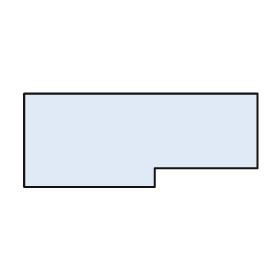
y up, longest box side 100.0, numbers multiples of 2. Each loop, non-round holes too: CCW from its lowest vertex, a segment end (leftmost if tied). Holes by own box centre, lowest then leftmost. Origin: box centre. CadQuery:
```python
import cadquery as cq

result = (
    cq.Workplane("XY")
    .moveTo(-50.0, -20.0)
    .lineTo(6.0, -20.0)
    .lineTo(6.0, -12.0)
    .lineTo(50.0, -12.0)
    .lineTo(50.0, 20.0)
    .lineTo(-50.0, 20.0)
    .close()
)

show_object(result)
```